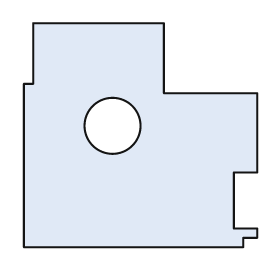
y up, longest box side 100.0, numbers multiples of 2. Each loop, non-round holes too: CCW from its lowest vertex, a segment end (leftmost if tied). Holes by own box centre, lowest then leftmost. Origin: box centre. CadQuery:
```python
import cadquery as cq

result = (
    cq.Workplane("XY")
    .moveTo(-50.0, -48.0)
    .lineTo(44.0, -48.0)
    .lineTo(44.0, -44.0)
    .lineTo(50.0, -44.0)
    .lineTo(50.0, -40.0)
    .lineTo(40.0, -40.0)
    .lineTo(40.0, -16.0)
    .lineTo(50.0, -16.0)
    .lineTo(50.0, 18.0)
    .lineTo(10.0, 18.0)
    .lineTo(10.0, 48.0)
    .lineTo(-46.0, 48.0)
    .lineTo(-46.0, 22.0)
    .lineTo(-50.0, 22.0)
    .close()
    .moveTo(-12.0, 4.0)
    .circle(12.0)
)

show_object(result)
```